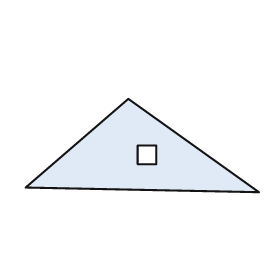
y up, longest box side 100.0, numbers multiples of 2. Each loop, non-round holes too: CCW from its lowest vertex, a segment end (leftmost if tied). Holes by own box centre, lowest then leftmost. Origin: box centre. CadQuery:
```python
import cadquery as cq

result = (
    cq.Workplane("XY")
    .moveTo(50.0, -20.0)
    .lineTo(-6.0, 20.0)
    .lineTo(-50.0, -18.0)
    .close()
    .moveTo(-2.0, -8.0)
    .lineTo(6.0, -8.0)
    .lineTo(6.0, 0.0)
    .lineTo(-2.0, 0.0)
    .close()
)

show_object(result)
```